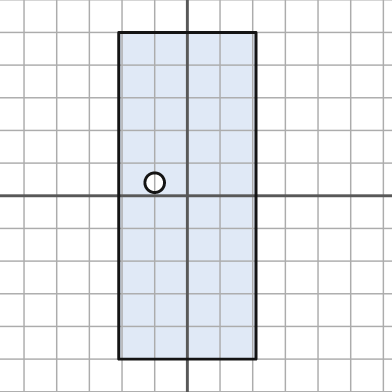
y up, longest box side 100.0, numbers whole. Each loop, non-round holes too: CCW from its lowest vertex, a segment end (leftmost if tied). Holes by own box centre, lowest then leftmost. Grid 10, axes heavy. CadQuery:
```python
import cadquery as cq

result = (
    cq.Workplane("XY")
    .moveTo(-21.0, -50.0)
    .lineTo(21.0, -50.0)
    .lineTo(21.0, 50.0)
    .lineTo(-21.0, 50.0)
    .close()
    .moveTo(-10.0, 4.0)
    .circle(3.0)
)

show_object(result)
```